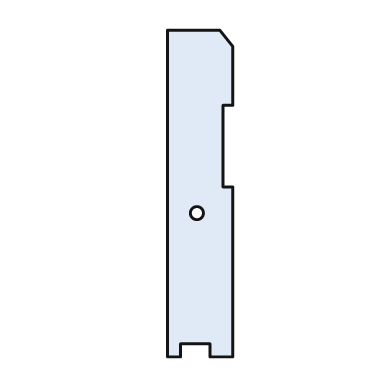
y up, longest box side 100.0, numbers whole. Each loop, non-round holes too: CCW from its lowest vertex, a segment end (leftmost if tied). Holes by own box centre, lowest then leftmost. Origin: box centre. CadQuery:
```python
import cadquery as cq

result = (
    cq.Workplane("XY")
    .moveTo(-10.0, -50.0)
    .lineTo(-6.0, -50.0)
    .lineTo(-6.0, -46.0)
    .lineTo(3.0, -46.0)
    .lineTo(3.0, -50.0)
    .lineTo(10.0, -50.0)
    .lineTo(10.0, 2.0)
    .lineTo(7.0, 2.0)
    .lineTo(7.0, 27.0)
    .lineTo(10.0, 27.0)
    .lineTo(10.0, 45.0)
    .lineTo(6.0, 50.0)
    .lineTo(-10.0, 50.0)
    .close()
    .moveTo(-1.0, -6.0)
    .circle(2.0)
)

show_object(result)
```